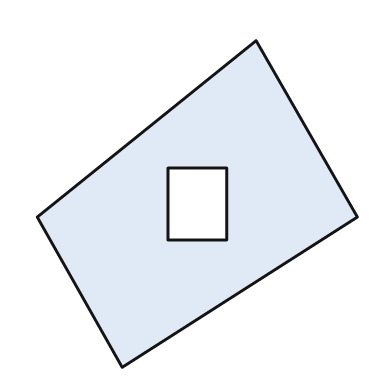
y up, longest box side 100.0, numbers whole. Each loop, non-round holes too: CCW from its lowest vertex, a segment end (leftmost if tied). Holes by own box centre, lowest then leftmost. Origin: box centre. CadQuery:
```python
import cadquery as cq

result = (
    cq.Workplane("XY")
    .moveTo(-23.0, -50.0)
    .lineTo(49.0, -4.0)
    .lineTo(18.0, 50.0)
    .lineTo(-49.0, -4.0)
    .close()
    .moveTo(-9.0, -11.0)
    .lineTo(9.0, -11.0)
    .lineTo(9.0, 11.0)
    .lineTo(-9.0, 11.0)
    .close()
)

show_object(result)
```